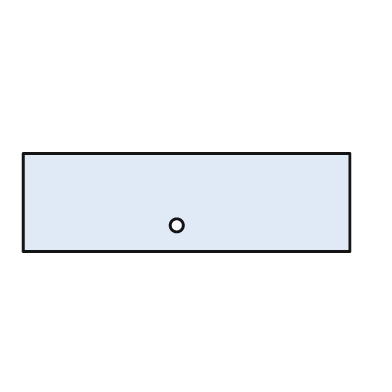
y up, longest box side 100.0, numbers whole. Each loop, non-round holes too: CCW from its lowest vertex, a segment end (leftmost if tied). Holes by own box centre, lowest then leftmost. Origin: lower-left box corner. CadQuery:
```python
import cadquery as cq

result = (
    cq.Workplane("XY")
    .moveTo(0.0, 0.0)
    .lineTo(100.0, 0.0)
    .lineTo(100.0, 30.0)
    .lineTo(0.0, 30.0)
    .close()
    .moveTo(47.0, 8.0)
    .circle(2.0)
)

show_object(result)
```